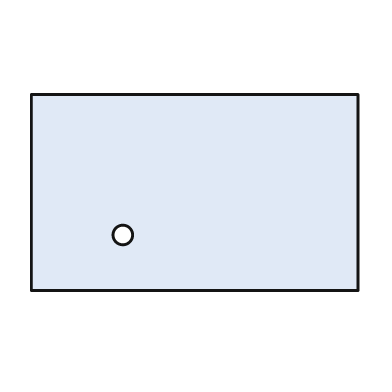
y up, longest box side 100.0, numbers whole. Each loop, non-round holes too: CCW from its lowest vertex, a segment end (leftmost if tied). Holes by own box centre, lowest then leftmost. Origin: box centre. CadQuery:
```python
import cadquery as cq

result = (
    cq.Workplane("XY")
    .moveTo(-50.0, -30.0)
    .lineTo(50.0, -30.0)
    .lineTo(50.0, 30.0)
    .lineTo(-50.0, 30.0)
    .close()
    .moveTo(-22.0, -13.0)
    .circle(3.0)
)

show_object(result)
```